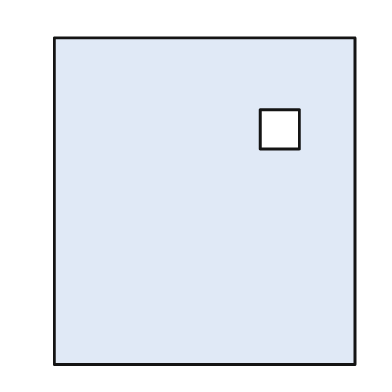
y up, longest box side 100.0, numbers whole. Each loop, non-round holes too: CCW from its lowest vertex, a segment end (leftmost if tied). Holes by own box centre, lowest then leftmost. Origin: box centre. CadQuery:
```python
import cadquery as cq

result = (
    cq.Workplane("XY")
    .moveTo(-46.0, -50.0)
    .lineTo(46.0, -50.0)
    .lineTo(46.0, 50.0)
    .lineTo(-46.0, 50.0)
    .close()
    .moveTo(17.0, 16.0)
    .lineTo(29.0, 16.0)
    .lineTo(29.0, 28.0)
    .lineTo(17.0, 28.0)
    .close()
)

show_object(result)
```